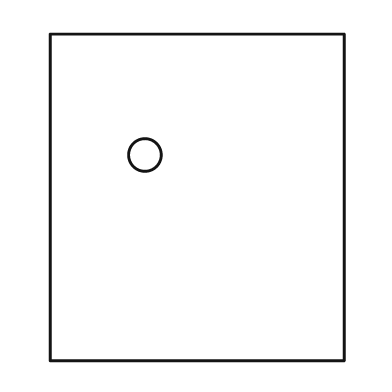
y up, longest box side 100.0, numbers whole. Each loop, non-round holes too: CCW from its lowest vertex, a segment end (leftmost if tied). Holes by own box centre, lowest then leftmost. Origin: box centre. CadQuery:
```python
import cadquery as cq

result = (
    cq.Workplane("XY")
    .moveTo(-45.0, -50.0)
    .lineTo(45.0, -50.0)
    .lineTo(45.0, 50.0)
    .lineTo(-45.0, 50.0)
    .close()
    .moveTo(-16.0, 13.0)
    .circle(5.0)
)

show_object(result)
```